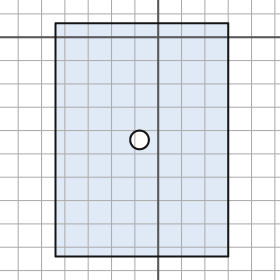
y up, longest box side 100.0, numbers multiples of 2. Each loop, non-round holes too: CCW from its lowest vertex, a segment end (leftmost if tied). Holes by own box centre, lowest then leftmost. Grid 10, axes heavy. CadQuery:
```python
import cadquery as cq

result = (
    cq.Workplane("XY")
    .moveTo(-44.0, -94.0)
    .lineTo(30.0, -94.0)
    .lineTo(30.0, 6.0)
    .lineTo(-44.0, 6.0)
    .close()
    .moveTo(-8.0, -44.0)
    .circle(4.0)
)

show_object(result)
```